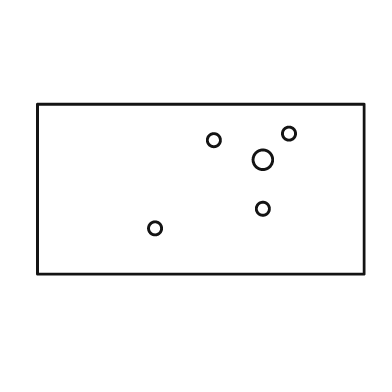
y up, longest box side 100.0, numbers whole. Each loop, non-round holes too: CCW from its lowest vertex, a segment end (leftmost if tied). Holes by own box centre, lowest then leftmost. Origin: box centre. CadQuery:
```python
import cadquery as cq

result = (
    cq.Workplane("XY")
    .moveTo(-50.0, -26.0)
    .lineTo(50.0, -26.0)
    .lineTo(50.0, 26.0)
    .lineTo(-50.0, 26.0)
    .close()
    .moveTo(-14.0, -12.0)
    .circle(2.0)
    .moveTo(19.0, -6.0)
    .circle(2.0)
    .moveTo(19.0, 9.0)
    .circle(3.0)
    .moveTo(4.0, 15.0)
    .circle(2.0)
    .moveTo(27.0, 17.0)
    .circle(2.0)
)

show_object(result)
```